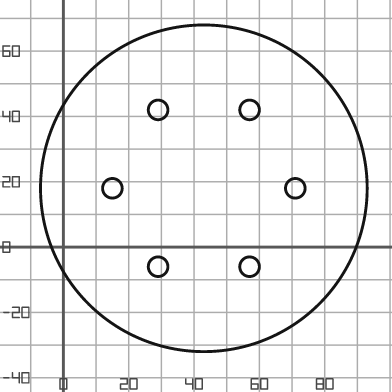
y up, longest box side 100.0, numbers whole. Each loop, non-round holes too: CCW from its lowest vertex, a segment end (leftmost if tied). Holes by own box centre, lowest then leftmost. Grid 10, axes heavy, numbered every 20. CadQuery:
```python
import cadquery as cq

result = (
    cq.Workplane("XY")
    .moveTo(43.0, 18.0)
    .circle(50.0)
    .moveTo(29.0, -6.0)
    .circle(3.0)
    .moveTo(57.0, -6.0)
    .circle(3.0)
    .moveTo(15.0, 18.0)
    .circle(3.0)
    .moveTo(71.0, 18.0)
    .circle(3.0)
    .moveTo(29.0, 42.0)
    .circle(3.0)
    .moveTo(57.0, 42.0)
    .circle(3.0)
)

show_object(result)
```